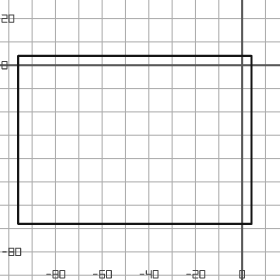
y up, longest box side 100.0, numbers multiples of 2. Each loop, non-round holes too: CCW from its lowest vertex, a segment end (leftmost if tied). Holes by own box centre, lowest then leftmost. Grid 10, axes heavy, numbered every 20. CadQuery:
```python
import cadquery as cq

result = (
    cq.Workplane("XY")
    .moveTo(-96.0, -68.0)
    .lineTo(4.0, -68.0)
    .lineTo(4.0, 4.0)
    .lineTo(-96.0, 4.0)
    .close()
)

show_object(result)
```